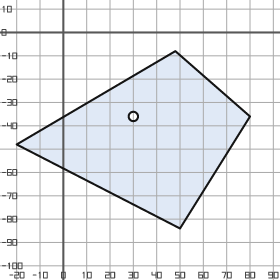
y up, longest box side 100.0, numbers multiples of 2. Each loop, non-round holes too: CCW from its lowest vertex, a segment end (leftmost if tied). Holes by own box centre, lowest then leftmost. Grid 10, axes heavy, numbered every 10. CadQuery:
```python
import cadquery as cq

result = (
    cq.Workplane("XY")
    .moveTo(50.0, -84.0)
    .lineTo(80.0, -36.0)
    .lineTo(48.0, -8.0)
    .lineTo(-20.0, -48.0)
    .close()
    .moveTo(30.0, -36.0)
    .circle(2.0)
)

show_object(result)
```